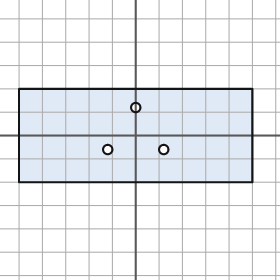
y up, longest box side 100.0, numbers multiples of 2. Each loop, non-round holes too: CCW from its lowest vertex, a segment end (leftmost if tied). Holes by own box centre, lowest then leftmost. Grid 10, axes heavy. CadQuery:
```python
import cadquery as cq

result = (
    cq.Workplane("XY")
    .moveTo(-50.0, -20.0)
    .lineTo(50.0, -20.0)
    .lineTo(50.0, 20.0)
    .lineTo(-50.0, 20.0)
    .close()
    .moveTo(-12.0, -6.0)
    .circle(2.0)
    .moveTo(12.0, -6.0)
    .circle(2.0)
    .moveTo(0.0, 12.0)
    .circle(2.0)
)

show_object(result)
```